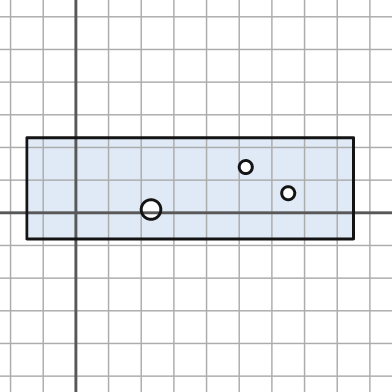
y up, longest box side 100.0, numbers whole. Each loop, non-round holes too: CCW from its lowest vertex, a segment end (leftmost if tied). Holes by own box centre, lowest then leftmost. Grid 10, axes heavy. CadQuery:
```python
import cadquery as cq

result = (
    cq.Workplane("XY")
    .moveTo(-15.0, -8.0)
    .lineTo(85.0, -8.0)
    .lineTo(85.0, 23.0)
    .lineTo(-15.0, 23.0)
    .close()
    .moveTo(23.0, 1.0)
    .circle(3.0)
    .moveTo(65.0, 6.0)
    .circle(2.0)
    .moveTo(52.0, 14.0)
    .circle(2.0)
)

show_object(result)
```